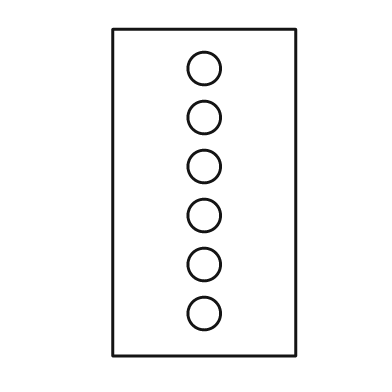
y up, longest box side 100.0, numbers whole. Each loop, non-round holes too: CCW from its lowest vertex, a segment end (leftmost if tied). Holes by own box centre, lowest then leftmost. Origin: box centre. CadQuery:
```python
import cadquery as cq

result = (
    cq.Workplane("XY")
    .moveTo(-28.0, -50.0)
    .lineTo(28.0, -50.0)
    .lineTo(28.0, 50.0)
    .lineTo(-28.0, 50.0)
    .close()
    .moveTo(0.0, -37.0)
    .circle(5.0)
    .moveTo(0.0, -22.0)
    .circle(5.0)
    .moveTo(0.0, -7.0)
    .circle(5.0)
    .moveTo(0.0, 8.0)
    .circle(5.0)
    .moveTo(0.0, 23.0)
    .circle(5.0)
    .moveTo(0.0, 38.0)
    .circle(5.0)
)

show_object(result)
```